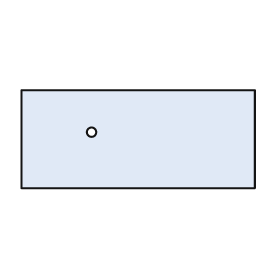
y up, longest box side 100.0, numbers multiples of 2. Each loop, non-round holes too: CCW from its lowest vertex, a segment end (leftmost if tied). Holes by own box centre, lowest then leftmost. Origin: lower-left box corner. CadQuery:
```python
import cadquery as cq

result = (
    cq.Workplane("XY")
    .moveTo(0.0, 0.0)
    .lineTo(100.0, 0.0)
    .lineTo(100.0, 42.0)
    .lineTo(0.0, 42.0)
    .close()
    .moveTo(30.0, 24.0)
    .circle(2.0)
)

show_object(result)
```